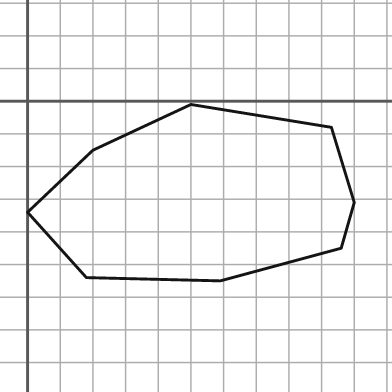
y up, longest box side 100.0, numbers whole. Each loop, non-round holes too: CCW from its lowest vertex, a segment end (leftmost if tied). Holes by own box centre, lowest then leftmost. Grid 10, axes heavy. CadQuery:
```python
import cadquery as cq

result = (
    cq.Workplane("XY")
    .moveTo(59.0, -55.0)
    .lineTo(96.0, -45.0)
    .lineTo(100.0, -31.0)
    .lineTo(93.0, -8.0)
    .lineTo(50.0, -1.0)
    .lineTo(20.0, -15.0)
    .lineTo(0.0, -34.0)
    .lineTo(18.0, -54.0)
    .close()
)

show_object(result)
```